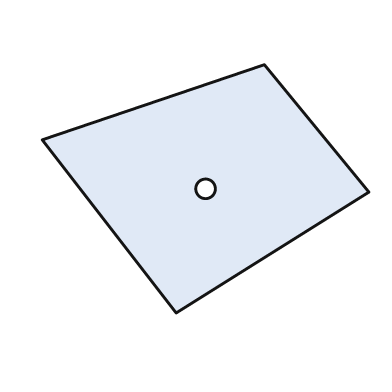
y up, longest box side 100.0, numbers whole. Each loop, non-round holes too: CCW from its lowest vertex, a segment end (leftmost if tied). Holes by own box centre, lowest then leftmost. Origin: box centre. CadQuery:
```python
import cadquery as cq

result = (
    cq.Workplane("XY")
    .moveTo(-9.0, -38.0)
    .lineTo(50.0, -1.0)
    .lineTo(18.0, 38.0)
    .lineTo(-50.0, 15.0)
    .close()
    .moveTo(0.0, 0.0)
    .circle(3.0)
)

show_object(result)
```